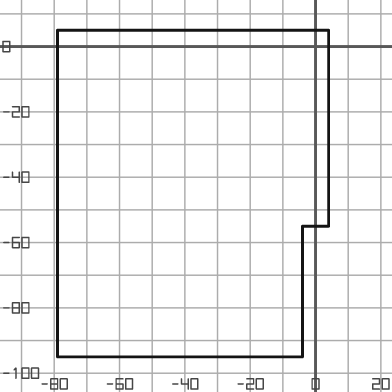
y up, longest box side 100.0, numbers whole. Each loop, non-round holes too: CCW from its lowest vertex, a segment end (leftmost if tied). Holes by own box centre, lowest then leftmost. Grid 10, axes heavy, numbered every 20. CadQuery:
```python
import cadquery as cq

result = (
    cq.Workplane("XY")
    .moveTo(-79.0, -95.0)
    .lineTo(-4.0, -95.0)
    .lineTo(-4.0, -55.0)
    .lineTo(4.0, -55.0)
    .lineTo(4.0, 5.0)
    .lineTo(-79.0, 5.0)
    .close()
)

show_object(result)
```